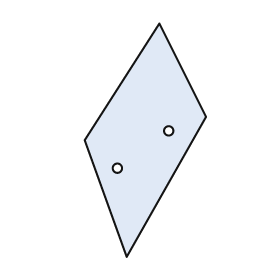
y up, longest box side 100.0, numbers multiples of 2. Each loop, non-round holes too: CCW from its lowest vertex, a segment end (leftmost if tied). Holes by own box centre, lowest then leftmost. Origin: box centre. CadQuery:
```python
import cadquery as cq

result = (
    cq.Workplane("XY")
    .moveTo(-8.0, -50.0)
    .lineTo(26.0, 10.0)
    .lineTo(6.0, 50.0)
    .lineTo(-26.0, 0.0)
    .close()
    .moveTo(-12.0, -12.0)
    .circle(2.0)
    .moveTo(10.0, 4.0)
    .circle(2.0)
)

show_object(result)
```